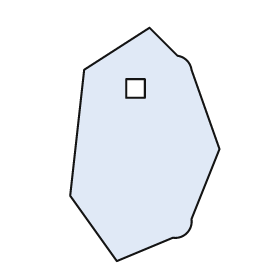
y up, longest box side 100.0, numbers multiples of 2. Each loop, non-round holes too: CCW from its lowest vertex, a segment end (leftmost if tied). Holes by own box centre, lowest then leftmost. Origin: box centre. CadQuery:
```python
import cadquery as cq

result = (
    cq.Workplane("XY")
    .moveTo(-12.0, -50.0)
    .lineTo(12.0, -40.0)
    .threePointArc((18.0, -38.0), (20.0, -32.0))
    .lineTo(32.0, -2.0)
    .lineTo(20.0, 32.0)
    .threePointArc((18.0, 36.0), (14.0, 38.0))
    .lineTo(2.0, 50.0)
    .lineTo(-26.0, 32.0)
    .lineTo(-32.0, -22.0)
    .close()
    .moveTo(-8.0, 20.0)
    .lineTo(0.0, 20.0)
    .lineTo(0.0, 28.0)
    .lineTo(-8.0, 28.0)
    .close()
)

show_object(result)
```